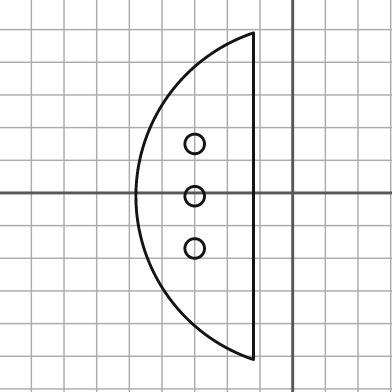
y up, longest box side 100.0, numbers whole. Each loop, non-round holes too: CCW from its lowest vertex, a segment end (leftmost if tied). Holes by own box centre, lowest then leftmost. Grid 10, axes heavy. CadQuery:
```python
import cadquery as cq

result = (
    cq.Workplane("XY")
    .moveTo(-12.0, -51.0)
    .lineTo(-12.0, 49.0)
    .threePointArc((-48.0, -1.0), (-12.0, -51.0))
    .close()
    .moveTo(-30.0, -17.0)
    .circle(3.0)
    .moveTo(-30.0, -1.0)
    .circle(3.0)
    .moveTo(-30.0, 15.0)
    .circle(3.0)
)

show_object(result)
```